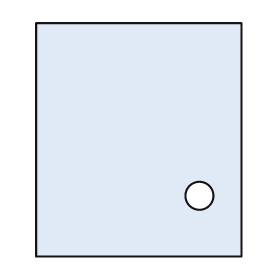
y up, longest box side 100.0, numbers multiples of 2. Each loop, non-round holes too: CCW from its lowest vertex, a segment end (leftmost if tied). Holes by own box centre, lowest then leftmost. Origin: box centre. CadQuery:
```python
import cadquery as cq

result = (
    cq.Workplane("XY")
    .moveTo(-44.0, -50.0)
    .lineTo(44.0, -50.0)
    .lineTo(44.0, 50.0)
    .lineTo(-44.0, 50.0)
    .close()
    .moveTo(26.0, -24.0)
    .circle(6.0)
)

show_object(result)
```